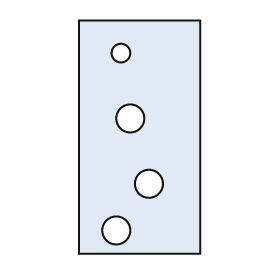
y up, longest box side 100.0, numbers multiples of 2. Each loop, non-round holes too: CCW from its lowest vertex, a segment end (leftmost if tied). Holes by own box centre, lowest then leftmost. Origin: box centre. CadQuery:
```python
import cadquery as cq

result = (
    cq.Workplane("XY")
    .moveTo(-26.0, -50.0)
    .lineTo(26.0, -50.0)
    .lineTo(26.0, 50.0)
    .lineTo(-26.0, 50.0)
    .close()
    .moveTo(-10.0, -40.0)
    .circle(6.0)
    .moveTo(4.0, -20.0)
    .circle(6.0)
    .moveTo(-4.0, 8.0)
    .circle(6.0)
    .moveTo(-8.0, 36.0)
    .circle(4.0)
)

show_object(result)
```